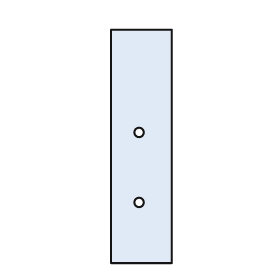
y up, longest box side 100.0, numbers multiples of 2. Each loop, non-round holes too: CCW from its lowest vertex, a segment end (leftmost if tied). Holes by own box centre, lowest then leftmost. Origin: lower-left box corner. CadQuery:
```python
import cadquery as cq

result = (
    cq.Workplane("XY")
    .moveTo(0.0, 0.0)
    .lineTo(26.0, 0.0)
    .lineTo(26.0, 100.0)
    .lineTo(0.0, 100.0)
    .close()
    .moveTo(12.0, 26.0)
    .circle(2.0)
    .moveTo(12.0, 56.0)
    .circle(2.0)
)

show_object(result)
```